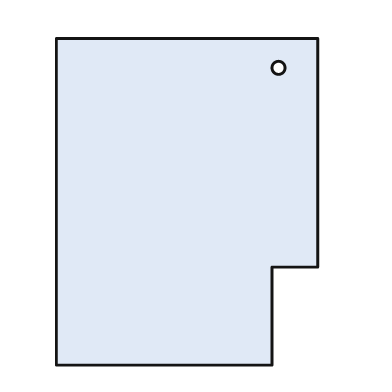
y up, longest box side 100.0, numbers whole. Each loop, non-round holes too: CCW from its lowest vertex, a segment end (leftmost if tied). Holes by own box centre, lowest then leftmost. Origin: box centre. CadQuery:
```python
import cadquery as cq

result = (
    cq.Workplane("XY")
    .moveTo(-40.0, -50.0)
    .lineTo(26.0, -50.0)
    .lineTo(26.0, -20.0)
    .lineTo(40.0, -20.0)
    .lineTo(40.0, 50.0)
    .lineTo(-40.0, 50.0)
    .close()
    .moveTo(28.0, 41.0)
    .circle(2.0)
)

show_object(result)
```